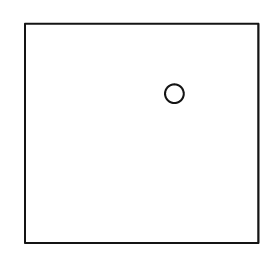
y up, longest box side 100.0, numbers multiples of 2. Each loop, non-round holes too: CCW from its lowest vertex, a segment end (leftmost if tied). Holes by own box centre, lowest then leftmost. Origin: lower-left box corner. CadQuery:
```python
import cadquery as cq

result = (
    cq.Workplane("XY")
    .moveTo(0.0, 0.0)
    .lineTo(100.0, 0.0)
    .lineTo(100.0, 94.0)
    .lineTo(0.0, 94.0)
    .close()
    .moveTo(64.0, 64.0)
    .circle(4.0)
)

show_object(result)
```